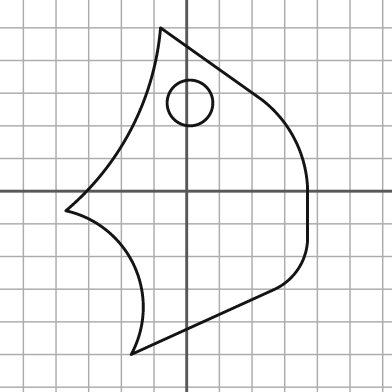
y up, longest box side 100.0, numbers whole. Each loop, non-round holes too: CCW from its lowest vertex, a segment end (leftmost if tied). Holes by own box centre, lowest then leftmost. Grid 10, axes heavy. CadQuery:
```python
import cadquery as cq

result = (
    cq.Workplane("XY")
    .moveTo(-17.0, -50.0)
    .lineTo(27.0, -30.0)
    .threePointArc((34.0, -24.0), (37.0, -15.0))
    .lineTo(37.0, 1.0)
    .threePointArc((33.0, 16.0), (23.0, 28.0))
    .lineTo(-8.0, 50.0)
    .threePointArc((-17.0, 19.0), (-37.0, -6.0))
    .threePointArc((-16.0, -23.0), (-17.0, -50.0))
    .close()
    .moveTo(1.0, 27.0)
    .circle(7.0)
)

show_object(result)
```